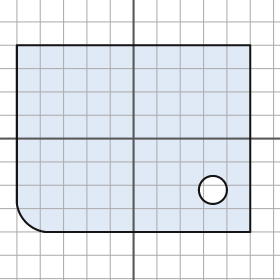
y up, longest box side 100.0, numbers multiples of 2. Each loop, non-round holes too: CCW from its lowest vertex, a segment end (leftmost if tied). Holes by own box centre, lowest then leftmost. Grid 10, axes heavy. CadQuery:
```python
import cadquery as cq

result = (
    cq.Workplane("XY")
    .moveTo(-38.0, -40.0)
    .lineTo(50.0, -40.0)
    .lineTo(50.0, 40.0)
    .lineTo(-50.0, 40.0)
    .lineTo(-50.0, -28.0)
    .threePointArc((-46.0, -36.0), (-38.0, -40.0))
    .close()
    .moveTo(34.0, -22.0)
    .circle(6.0)
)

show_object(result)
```